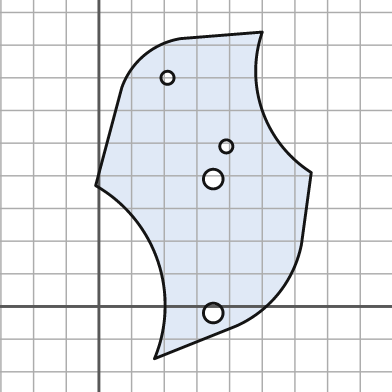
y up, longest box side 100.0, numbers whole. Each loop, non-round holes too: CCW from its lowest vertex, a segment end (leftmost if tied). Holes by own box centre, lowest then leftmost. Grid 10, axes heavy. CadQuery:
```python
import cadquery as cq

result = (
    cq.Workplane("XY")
    .moveTo(17.0, -16.0)
    .lineTo(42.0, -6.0)
    .threePointArc((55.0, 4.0), (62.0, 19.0))
    .lineTo(65.0, 41.0)
    .threePointArc((50.0, 60.0), (50.0, 84.0))
    .lineTo(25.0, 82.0)
    .threePointArc((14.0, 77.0), (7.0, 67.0))
    .lineTo(-1.0, 37.0)
    .threePointArc((18.0, 14.0), (17.0, -16.0))
    .close()
    .moveTo(35.0, -2.0)
    .circle(3.0)
    .moveTo(35.0, 39.0)
    .circle(3.0)
    .moveTo(39.0, 49.0)
    .circle(2.0)
    .moveTo(21.0, 70.0)
    .circle(2.0)
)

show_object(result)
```